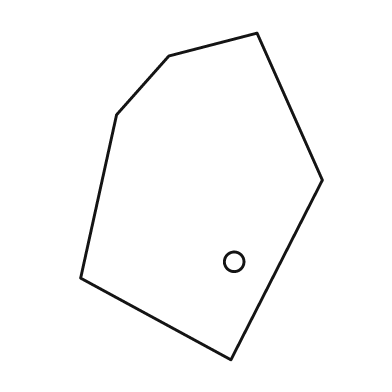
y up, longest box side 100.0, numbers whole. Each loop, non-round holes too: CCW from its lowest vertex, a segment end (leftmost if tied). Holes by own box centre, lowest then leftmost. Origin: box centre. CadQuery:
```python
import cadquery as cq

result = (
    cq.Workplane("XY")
    .moveTo(9.0, -50.0)
    .lineTo(37.0, 5.0)
    .lineTo(17.0, 50.0)
    .lineTo(-10.0, 43.0)
    .lineTo(-26.0, 25.0)
    .lineTo(-37.0, -25.0)
    .close()
    .moveTo(10.0, -20.0)
    .circle(3.0)
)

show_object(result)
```